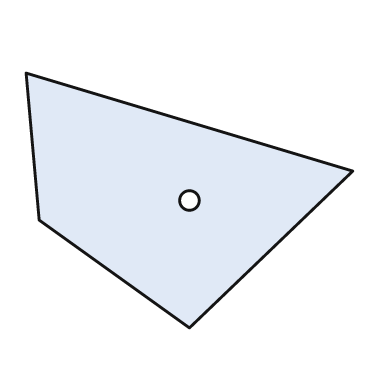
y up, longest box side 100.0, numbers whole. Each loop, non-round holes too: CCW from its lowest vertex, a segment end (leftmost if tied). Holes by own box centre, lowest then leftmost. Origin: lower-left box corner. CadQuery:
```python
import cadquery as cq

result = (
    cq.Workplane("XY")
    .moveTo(50.0, 0.0)
    .lineTo(100.0, 48.0)
    .lineTo(0.0, 78.0)
    .lineTo(4.0, 33.0)
    .close()
    .moveTo(50.0, 39.0)
    .circle(3.0)
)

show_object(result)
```